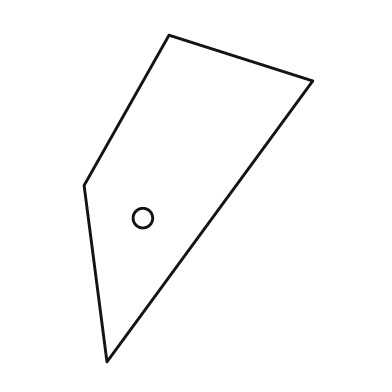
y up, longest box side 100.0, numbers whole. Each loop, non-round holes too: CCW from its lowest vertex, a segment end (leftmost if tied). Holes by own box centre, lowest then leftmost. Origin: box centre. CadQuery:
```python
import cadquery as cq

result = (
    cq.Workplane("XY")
    .moveTo(-28.0, -50.0)
    .lineTo(35.0, 36.0)
    .lineTo(-9.0, 50.0)
    .lineTo(-35.0, 4.0)
    .close()
    .moveTo(-17.0, -6.0)
    .circle(3.0)
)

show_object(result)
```